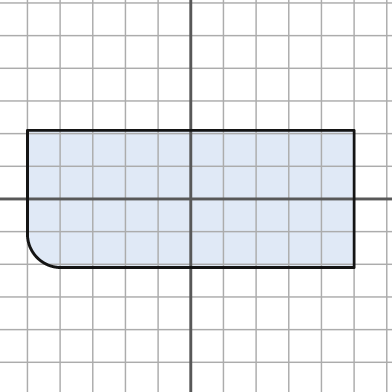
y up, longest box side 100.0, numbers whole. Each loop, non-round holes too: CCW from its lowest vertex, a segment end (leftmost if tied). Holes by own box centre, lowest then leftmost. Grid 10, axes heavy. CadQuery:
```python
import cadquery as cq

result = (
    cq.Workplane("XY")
    .moveTo(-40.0, -21.0)
    .lineTo(50.0, -21.0)
    .lineTo(50.0, 21.0)
    .lineTo(-50.0, 21.0)
    .lineTo(-50.0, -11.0)
    .threePointArc((-47.0, -18.0), (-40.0, -21.0))
    .close()
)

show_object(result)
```